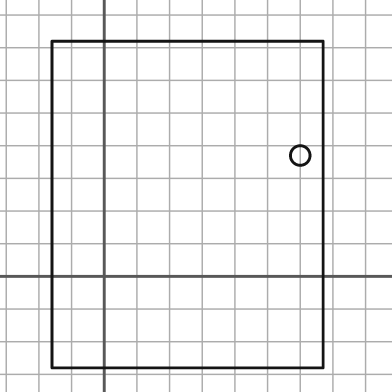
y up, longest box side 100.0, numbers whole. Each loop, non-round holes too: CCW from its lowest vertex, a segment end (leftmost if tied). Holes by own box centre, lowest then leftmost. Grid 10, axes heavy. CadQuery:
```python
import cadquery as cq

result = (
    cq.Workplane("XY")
    .moveTo(-16.0, -28.0)
    .lineTo(67.0, -28.0)
    .lineTo(67.0, 72.0)
    .lineTo(-16.0, 72.0)
    .close()
    .moveTo(60.0, 37.0)
    .circle(3.0)
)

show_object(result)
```